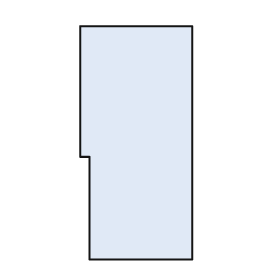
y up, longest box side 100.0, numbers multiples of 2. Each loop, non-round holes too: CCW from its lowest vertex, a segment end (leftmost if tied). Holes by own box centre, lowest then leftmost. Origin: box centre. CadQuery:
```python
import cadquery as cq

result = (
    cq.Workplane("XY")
    .moveTo(-20.0, -50.0)
    .lineTo(24.0, -50.0)
    .lineTo(24.0, 50.0)
    .lineTo(-24.0, 50.0)
    .lineTo(-24.0, -6.0)
    .lineTo(-20.0, -6.0)
    .close()
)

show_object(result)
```